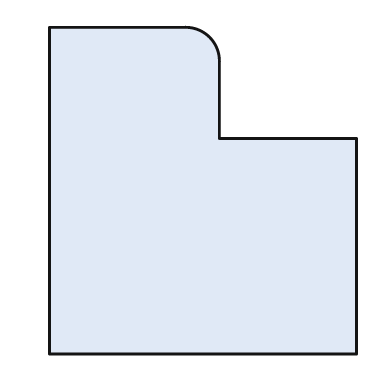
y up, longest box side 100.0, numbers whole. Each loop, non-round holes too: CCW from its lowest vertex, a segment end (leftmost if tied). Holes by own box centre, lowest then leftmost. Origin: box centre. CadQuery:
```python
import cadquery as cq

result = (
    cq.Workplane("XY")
    .moveTo(-47.0, -50.0)
    .lineTo(47.0, -50.0)
    .lineTo(47.0, 16.0)
    .lineTo(5.0, 16.0)
    .lineTo(5.0, 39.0)
    .threePointArc((2.0, 47.0), (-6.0, 50.0))
    .lineTo(-47.0, 50.0)
    .close()
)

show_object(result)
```